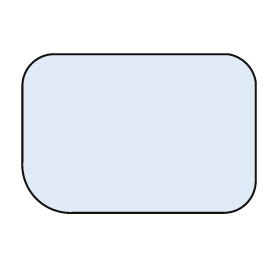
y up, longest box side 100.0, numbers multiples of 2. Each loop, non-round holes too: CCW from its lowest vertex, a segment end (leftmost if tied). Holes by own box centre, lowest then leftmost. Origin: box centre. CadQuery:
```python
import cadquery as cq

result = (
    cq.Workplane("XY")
    .moveTo(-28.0, -34.0)
    .lineTo(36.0, -34.0)
    .threePointArc((46.0, -30.0), (50.0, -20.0))
    .lineTo(50.0, 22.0)
    .threePointArc((46.0, 30.0), (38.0, 34.0))
    .lineTo(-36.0, 34.0)
    .threePointArc((-46.0, 30.0), (-50.0, 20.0))
    .lineTo(-50.0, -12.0)
    .threePointArc((-44.0, -28.0), (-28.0, -34.0))
    .close()
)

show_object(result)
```